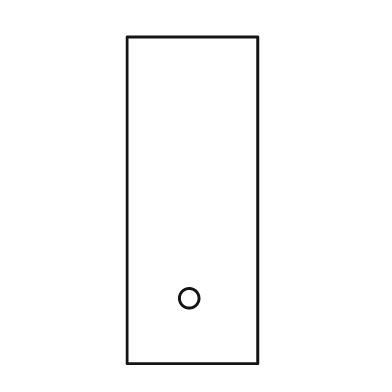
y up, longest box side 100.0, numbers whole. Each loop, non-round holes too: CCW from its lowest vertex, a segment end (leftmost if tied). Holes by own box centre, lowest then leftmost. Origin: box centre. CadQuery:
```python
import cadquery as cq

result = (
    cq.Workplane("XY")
    .moveTo(-20.0, -50.0)
    .lineTo(20.0, -50.0)
    .lineTo(20.0, 50.0)
    .lineTo(-20.0, 50.0)
    .close()
    .moveTo(-1.0, -30.0)
    .circle(3.0)
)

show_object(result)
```